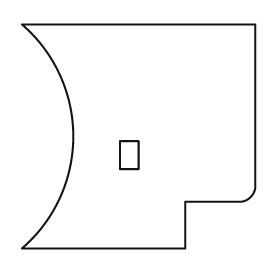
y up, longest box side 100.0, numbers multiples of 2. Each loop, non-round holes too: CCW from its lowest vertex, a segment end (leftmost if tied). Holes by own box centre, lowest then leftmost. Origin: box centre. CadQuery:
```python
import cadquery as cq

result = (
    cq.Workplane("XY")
    .moveTo(-50.0, -48.0)
    .lineTo(20.0, -48.0)
    .lineTo(20.0, -28.0)
    .lineTo(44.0, -28.0)
    .threePointArc((48.0, -26.0), (50.0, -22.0))
    .lineTo(50.0, 48.0)
    .lineTo(-50.0, 48.0)
    .threePointArc((-28.0, 0.0), (-50.0, -48.0))
    .close()
    .moveTo(-8.0, -14.0)
    .lineTo(0.0, -14.0)
    .lineTo(0.0, -2.0)
    .lineTo(-8.0, -2.0)
    .close()
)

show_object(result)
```